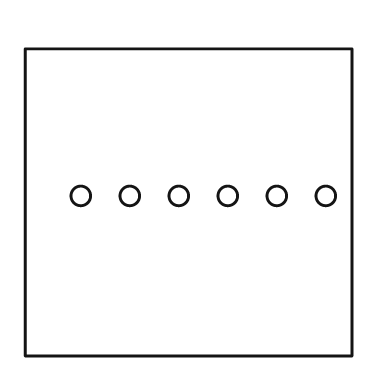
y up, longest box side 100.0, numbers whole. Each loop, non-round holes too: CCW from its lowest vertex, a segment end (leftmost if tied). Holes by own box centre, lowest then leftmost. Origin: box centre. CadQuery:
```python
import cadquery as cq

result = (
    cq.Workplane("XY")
    .moveTo(-50.0, -47.0)
    .lineTo(50.0, -47.0)
    .lineTo(50.0, 47.0)
    .lineTo(-50.0, 47.0)
    .close()
    .moveTo(-33.0, 2.0)
    .circle(3.0)
    .moveTo(-18.0, 2.0)
    .circle(3.0)
    .moveTo(-3.0, 2.0)
    .circle(3.0)
    .moveTo(12.0, 2.0)
    .circle(3.0)
    .moveTo(27.0, 2.0)
    .circle(3.0)
    .moveTo(42.0, 2.0)
    .circle(3.0)
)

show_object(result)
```